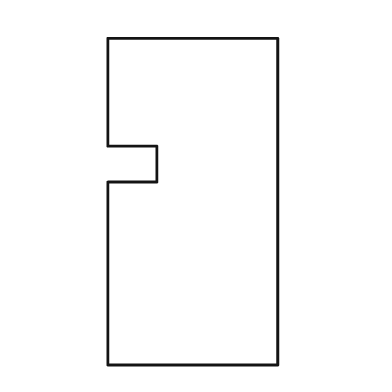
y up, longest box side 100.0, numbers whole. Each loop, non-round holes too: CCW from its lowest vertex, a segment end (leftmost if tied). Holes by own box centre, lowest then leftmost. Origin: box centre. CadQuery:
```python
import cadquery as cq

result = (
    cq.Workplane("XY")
    .moveTo(-26.0, -50.0)
    .lineTo(26.0, -50.0)
    .lineTo(26.0, 50.0)
    .lineTo(-26.0, 50.0)
    .lineTo(-26.0, 17.0)
    .lineTo(-11.0, 17.0)
    .lineTo(-11.0, 6.0)
    .lineTo(-26.0, 6.0)
    .close()
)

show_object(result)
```